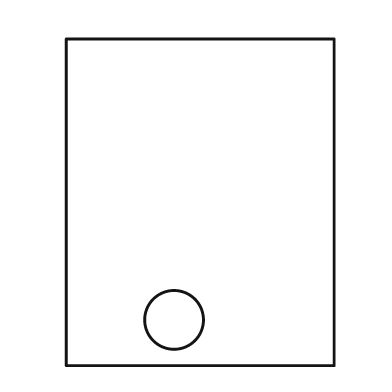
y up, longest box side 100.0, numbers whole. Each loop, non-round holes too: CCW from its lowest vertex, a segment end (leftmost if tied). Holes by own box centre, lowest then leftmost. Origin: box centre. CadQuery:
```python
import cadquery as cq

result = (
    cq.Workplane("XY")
    .moveTo(-41.0, -50.0)
    .lineTo(41.0, -50.0)
    .lineTo(41.0, 50.0)
    .lineTo(-41.0, 50.0)
    .close()
    .moveTo(-8.0, -36.0)
    .circle(9.0)
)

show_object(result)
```